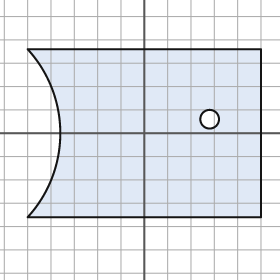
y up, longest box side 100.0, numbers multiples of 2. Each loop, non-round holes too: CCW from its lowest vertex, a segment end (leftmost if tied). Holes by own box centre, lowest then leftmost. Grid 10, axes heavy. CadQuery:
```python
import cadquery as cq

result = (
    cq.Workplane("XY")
    .moveTo(-50.0, -36.0)
    .lineTo(50.0, -36.0)
    .lineTo(50.0, 36.0)
    .lineTo(-50.0, 36.0)
    .threePointArc((-36.0, 0.0), (-50.0, -36.0))
    .close()
    .moveTo(28.0, 6.0)
    .circle(4.0)
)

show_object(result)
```